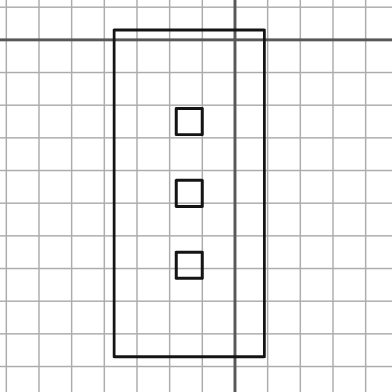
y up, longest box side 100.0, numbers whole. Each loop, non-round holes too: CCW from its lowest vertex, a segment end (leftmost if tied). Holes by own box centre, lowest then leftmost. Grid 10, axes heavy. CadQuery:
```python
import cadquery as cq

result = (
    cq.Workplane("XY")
    .moveTo(-37.0, -97.0)
    .lineTo(9.0, -97.0)
    .lineTo(9.0, 3.0)
    .lineTo(-37.0, 3.0)
    .close()
    .moveTo(-18.0, -73.0)
    .lineTo(-10.0, -73.0)
    .lineTo(-10.0, -65.0)
    .lineTo(-18.0, -65.0)
    .close()
    .moveTo(-18.0, -51.0)
    .lineTo(-10.0, -51.0)
    .lineTo(-10.0, -43.0)
    .lineTo(-18.0, -43.0)
    .close()
    .moveTo(-18.0, -29.0)
    .lineTo(-10.0, -29.0)
    .lineTo(-10.0, -21.0)
    .lineTo(-18.0, -21.0)
    .close()
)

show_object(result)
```